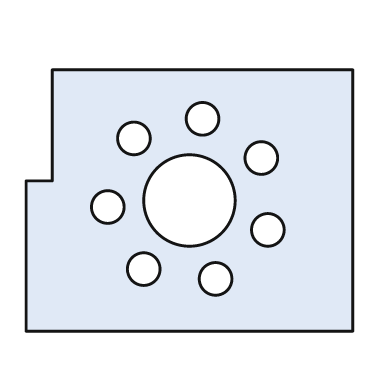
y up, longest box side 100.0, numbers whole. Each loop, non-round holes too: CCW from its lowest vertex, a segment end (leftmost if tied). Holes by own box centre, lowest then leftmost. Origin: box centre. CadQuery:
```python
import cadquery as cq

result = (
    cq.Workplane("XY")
    .moveTo(-50.0, -40.0)
    .lineTo(50.0, -40.0)
    .lineTo(50.0, 40.0)
    .lineTo(-42.0, 40.0)
    .lineTo(-42.0, 6.0)
    .lineTo(-50.0, 6.0)
    .close()
    .moveTo(8.0, -24.0)
    .circle(5.0)
    .moveTo(-14.0, -21.0)
    .circle(5.0)
    .moveTo(24.0, -9.0)
    .circle(5.0)
    .moveTo(-25.0, -2.0)
    .circle(5.0)
    .moveTo(0.0, 0.0)
    .circle(14.0)
    .moveTo(22.0, 13.0)
    .circle(5.0)
    .moveTo(-17.0, 19.0)
    .circle(5.0)
    .moveTo(4.0, 25.0)
    .circle(5.0)
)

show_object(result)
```